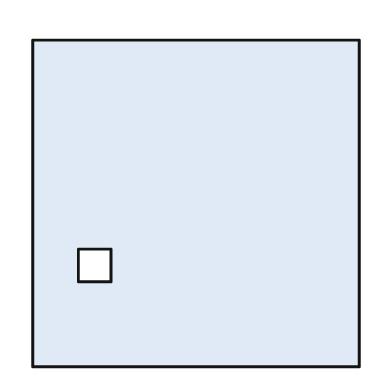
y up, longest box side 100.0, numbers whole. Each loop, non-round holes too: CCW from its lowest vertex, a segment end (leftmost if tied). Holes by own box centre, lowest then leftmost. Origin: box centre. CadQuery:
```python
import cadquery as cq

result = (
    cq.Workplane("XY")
    .moveTo(-50.0, -50.0)
    .lineTo(50.0, -50.0)
    .lineTo(50.0, 50.0)
    .lineTo(-50.0, 50.0)
    .close()
    .moveTo(-36.0, -24.0)
    .lineTo(-26.0, -24.0)
    .lineTo(-26.0, -14.0)
    .lineTo(-36.0, -14.0)
    .close()
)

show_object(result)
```